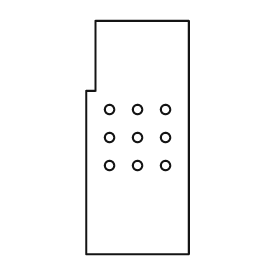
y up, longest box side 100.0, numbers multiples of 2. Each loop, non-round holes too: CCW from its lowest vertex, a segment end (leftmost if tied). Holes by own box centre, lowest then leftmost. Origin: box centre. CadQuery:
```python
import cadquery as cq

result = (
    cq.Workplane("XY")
    .moveTo(-22.0, -50.0)
    .lineTo(22.0, -50.0)
    .lineTo(22.0, 50.0)
    .lineTo(-18.0, 50.0)
    .lineTo(-18.0, 20.0)
    .lineTo(-22.0, 20.0)
    .close()
    .moveTo(-12.0, -12.0)
    .circle(2.0)
    .moveTo(0.0, -12.0)
    .circle(2.0)
    .moveTo(12.0, -12.0)
    .circle(2.0)
    .moveTo(-12.0, 0.0)
    .circle(2.0)
    .moveTo(0.0, 0.0)
    .circle(2.0)
    .moveTo(12.0, 0.0)
    .circle(2.0)
    .moveTo(-12.0, 12.0)
    .circle(2.0)
    .moveTo(0.0, 12.0)
    .circle(2.0)
    .moveTo(12.0, 12.0)
    .circle(2.0)
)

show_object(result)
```